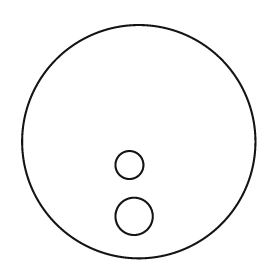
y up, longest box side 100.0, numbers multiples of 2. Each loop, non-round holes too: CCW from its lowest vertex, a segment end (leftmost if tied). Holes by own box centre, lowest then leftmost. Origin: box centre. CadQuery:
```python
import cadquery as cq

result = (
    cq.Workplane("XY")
    .moveTo(0.0, 0.0)
    .circle(50.0)
    .moveTo(-2.0, -32.0)
    .circle(8.0)
    .moveTo(-4.0, -10.0)
    .circle(6.0)
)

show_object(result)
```